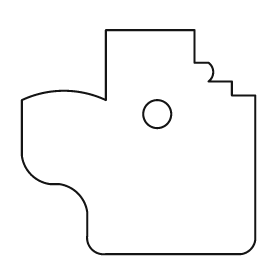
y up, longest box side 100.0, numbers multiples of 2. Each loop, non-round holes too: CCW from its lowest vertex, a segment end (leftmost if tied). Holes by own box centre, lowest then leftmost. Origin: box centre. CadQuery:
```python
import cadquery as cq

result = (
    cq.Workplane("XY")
    .moveTo(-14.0, -48.0)
    .lineTo(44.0, -48.0)
    .threePointArc((48.0, -46.0), (50.0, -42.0))
    .lineTo(50.0, 20.0)
    .lineTo(40.0, 20.0)
    .lineTo(40.0, 26.0)
    .lineTo(30.0, 26.0)
    .threePointArc((32.0, 30.0), (30.0, 34.0))
    .lineTo(24.0, 34.0)
    .lineTo(24.0, 48.0)
    .lineTo(-14.0, 48.0)
    .lineTo(-14.0, 18.0)
    .threePointArc((-32.0, 22.0), (-50.0, 18.0))
    .lineTo(-50.0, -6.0)
    .threePointArc((-46.0, -14.0), (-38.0, -18.0))
    .lineTo(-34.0, -18.0)
    .threePointArc((-26.0, -22.0), (-22.0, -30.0))
    .lineTo(-22.0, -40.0)
    .threePointArc((-20.0, -46.0), (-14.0, -48.0))
    .close()
    .moveTo(8.0, 12.0)
    .circle(6.0)
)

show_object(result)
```